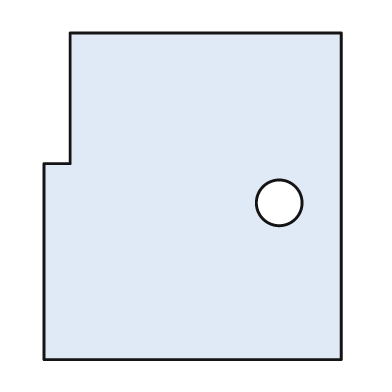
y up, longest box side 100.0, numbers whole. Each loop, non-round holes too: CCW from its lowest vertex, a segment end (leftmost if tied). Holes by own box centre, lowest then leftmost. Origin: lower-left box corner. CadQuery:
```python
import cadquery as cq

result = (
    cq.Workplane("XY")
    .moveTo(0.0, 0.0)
    .lineTo(91.0, 0.0)
    .lineTo(91.0, 100.0)
    .lineTo(8.0, 100.0)
    .lineTo(8.0, 60.0)
    .lineTo(0.0, 60.0)
    .close()
    .moveTo(72.0, 48.0)
    .circle(7.0)
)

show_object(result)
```